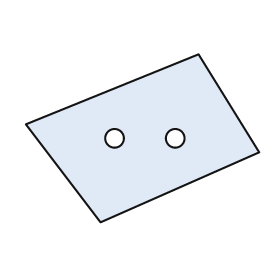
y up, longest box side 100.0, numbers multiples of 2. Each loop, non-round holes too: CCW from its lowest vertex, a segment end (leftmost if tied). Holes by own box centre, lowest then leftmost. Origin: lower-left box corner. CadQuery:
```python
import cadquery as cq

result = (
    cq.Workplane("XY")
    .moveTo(32.0, 0.0)
    .lineTo(100.0, 30.0)
    .lineTo(74.0, 72.0)
    .lineTo(0.0, 42.0)
    .close()
    .moveTo(38.0, 36.0)
    .circle(4.0)
    .moveTo(64.0, 36.0)
    .circle(4.0)
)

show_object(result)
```